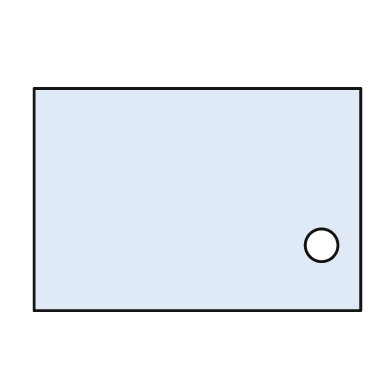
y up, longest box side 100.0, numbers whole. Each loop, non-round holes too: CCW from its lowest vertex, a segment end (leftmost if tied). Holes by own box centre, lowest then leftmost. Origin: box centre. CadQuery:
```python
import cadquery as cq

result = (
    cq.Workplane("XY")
    .moveTo(-50.0, -34.0)
    .lineTo(50.0, -34.0)
    .lineTo(50.0, 34.0)
    .lineTo(-50.0, 34.0)
    .close()
    .moveTo(38.0, -14.0)
    .circle(5.0)
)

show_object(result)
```